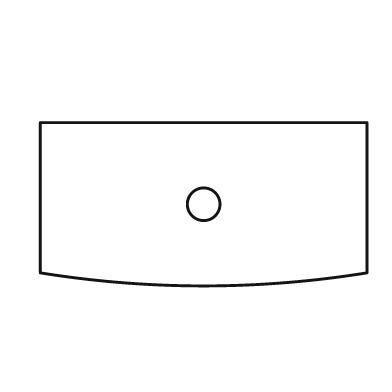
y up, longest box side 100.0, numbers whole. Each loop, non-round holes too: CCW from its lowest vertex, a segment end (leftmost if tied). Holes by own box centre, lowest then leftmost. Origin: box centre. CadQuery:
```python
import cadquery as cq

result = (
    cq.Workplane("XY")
    .moveTo(-50.0, -21.0)
    .threePointArc((0.0, -25.0), (50.0, -21.0))
    .lineTo(50.0, 25.0)
    .lineTo(-50.0, 25.0)
    .close()
    .moveTo(0.0, 0.0)
    .circle(5.0)
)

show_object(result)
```